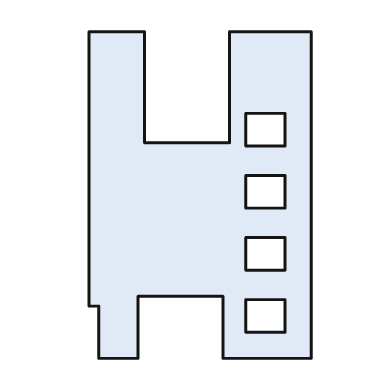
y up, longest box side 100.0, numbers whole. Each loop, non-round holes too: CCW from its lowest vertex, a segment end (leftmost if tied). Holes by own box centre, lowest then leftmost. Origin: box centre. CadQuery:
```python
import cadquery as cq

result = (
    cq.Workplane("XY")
    .moveTo(-31.0, -50.0)
    .lineTo(-19.0, -50.0)
    .lineTo(-19.0, -31.0)
    .lineTo(7.0, -31.0)
    .lineTo(7.0, -50.0)
    .lineTo(34.0, -50.0)
    .lineTo(34.0, 50.0)
    .lineTo(9.0, 50.0)
    .lineTo(9.0, 16.0)
    .lineTo(-17.0, 16.0)
    .lineTo(-17.0, 50.0)
    .lineTo(-34.0, 50.0)
    .lineTo(-34.0, -34.0)
    .lineTo(-31.0, -34.0)
    .close()
    .moveTo(14.0, -42.0)
    .lineTo(26.0, -42.0)
    .lineTo(26.0, -32.0)
    .lineTo(14.0, -32.0)
    .close()
    .moveTo(14.0, -23.0)
    .lineTo(26.0, -23.0)
    .lineTo(26.0, -13.0)
    .lineTo(14.0, -13.0)
    .close()
    .moveTo(14.0, -4.0)
    .lineTo(26.0, -4.0)
    .lineTo(26.0, 6.0)
    .lineTo(14.0, 6.0)
    .close()
    .moveTo(14.0, 15.0)
    .lineTo(26.0, 15.0)
    .lineTo(26.0, 25.0)
    .lineTo(14.0, 25.0)
    .close()
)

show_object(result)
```